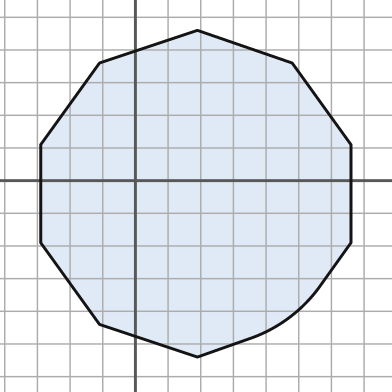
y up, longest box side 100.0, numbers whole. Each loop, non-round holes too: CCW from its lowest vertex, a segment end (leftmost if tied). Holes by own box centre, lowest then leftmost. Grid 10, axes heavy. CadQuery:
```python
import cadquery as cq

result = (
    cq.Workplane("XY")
    .moveTo(19.0, -54.0)
    .lineTo(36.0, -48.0)
    .threePointArc((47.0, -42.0), (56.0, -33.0))
    .lineTo(66.0, -19.0)
    .lineTo(66.0, 11.0)
    .lineTo(48.0, 36.0)
    .lineTo(19.0, 46.0)
    .lineTo(-11.0, 36.0)
    .lineTo(-29.0, 11.0)
    .lineTo(-29.0, -19.0)
    .lineTo(-11.0, -44.0)
    .close()
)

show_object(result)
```